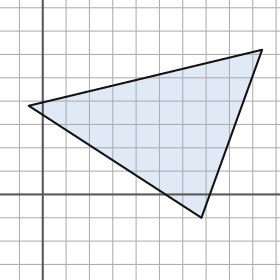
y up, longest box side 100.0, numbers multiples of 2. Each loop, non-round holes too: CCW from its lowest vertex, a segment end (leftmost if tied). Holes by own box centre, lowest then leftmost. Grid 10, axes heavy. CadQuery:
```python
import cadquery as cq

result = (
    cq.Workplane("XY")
    .moveTo(68.0, -10.0)
    .lineTo(94.0, 62.0)
    .lineTo(-6.0, 38.0)
    .close()
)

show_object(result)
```